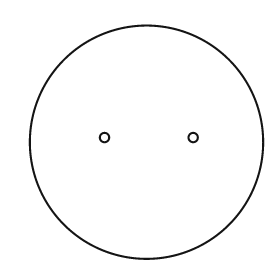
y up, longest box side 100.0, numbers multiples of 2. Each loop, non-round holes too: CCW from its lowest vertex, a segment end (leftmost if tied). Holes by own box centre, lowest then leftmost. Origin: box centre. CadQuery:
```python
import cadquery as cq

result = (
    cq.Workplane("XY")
    .moveTo(0.0, 0.0)
    .circle(50.0)
    .moveTo(-18.0, 2.0)
    .circle(2.0)
    .moveTo(20.0, 2.0)
    .circle(2.0)
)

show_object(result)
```